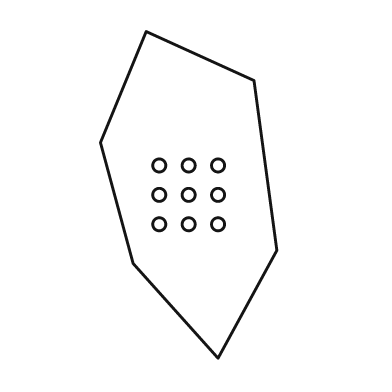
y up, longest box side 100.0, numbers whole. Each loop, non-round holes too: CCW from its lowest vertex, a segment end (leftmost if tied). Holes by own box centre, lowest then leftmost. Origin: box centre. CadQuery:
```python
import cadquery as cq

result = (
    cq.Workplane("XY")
    .moveTo(9.0, -50.0)
    .lineTo(27.0, -17.0)
    .lineTo(20.0, 35.0)
    .lineTo(-13.0, 50.0)
    .lineTo(-27.0, 16.0)
    .lineTo(-17.0, -21.0)
    .close()
    .moveTo(-9.0, -9.0)
    .circle(2.0)
    .moveTo(0.0, -9.0)
    .circle(2.0)
    .moveTo(9.0, -9.0)
    .circle(2.0)
    .moveTo(-9.0, 0.0)
    .circle(2.0)
    .moveTo(0.0, 0.0)
    .circle(2.0)
    .moveTo(9.0, 0.0)
    .circle(2.0)
    .moveTo(-9.0, 9.0)
    .circle(2.0)
    .moveTo(0.0, 9.0)
    .circle(2.0)
    .moveTo(9.0, 9.0)
    .circle(2.0)
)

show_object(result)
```